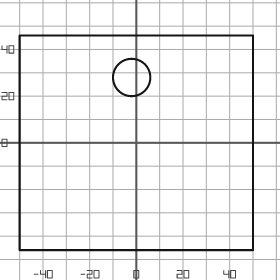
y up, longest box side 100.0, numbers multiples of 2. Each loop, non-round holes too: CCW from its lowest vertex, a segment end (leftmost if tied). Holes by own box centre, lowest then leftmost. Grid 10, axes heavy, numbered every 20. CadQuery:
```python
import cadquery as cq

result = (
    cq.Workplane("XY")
    .moveTo(-50.0, -46.0)
    .lineTo(50.0, -46.0)
    .lineTo(50.0, 46.0)
    .lineTo(-50.0, 46.0)
    .close()
    .moveTo(-2.0, 28.0)
    .circle(8.0)
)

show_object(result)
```